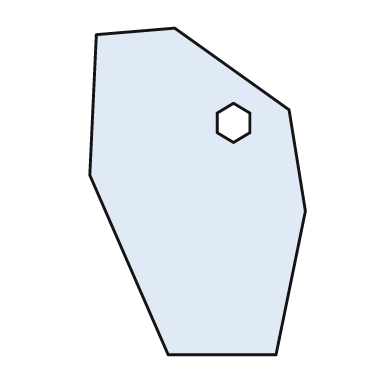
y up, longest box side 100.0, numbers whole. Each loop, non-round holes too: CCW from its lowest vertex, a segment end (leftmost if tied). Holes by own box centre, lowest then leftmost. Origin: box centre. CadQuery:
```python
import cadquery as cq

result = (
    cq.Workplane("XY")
    .moveTo(-9.0, -50.0)
    .lineTo(24.0, -50.0)
    .lineTo(33.0, -6.0)
    .lineTo(28.0, 25.0)
    .lineTo(-7.0, 50.0)
    .lineTo(-31.0, 48.0)
    .lineTo(-33.0, 5.0)
    .close()
    .moveTo(11.0, 15.0)
    .lineTo(16.0, 18.0)
    .lineTo(16.0, 24.0)
    .lineTo(11.0, 27.0)
    .lineTo(6.0, 24.0)
    .lineTo(6.0, 18.0)
    .close()
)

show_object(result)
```